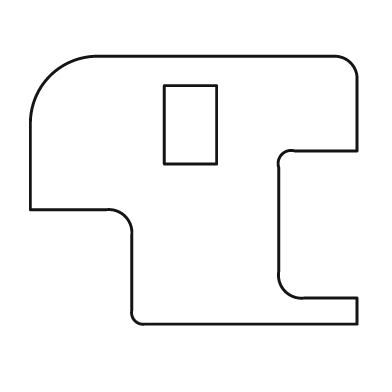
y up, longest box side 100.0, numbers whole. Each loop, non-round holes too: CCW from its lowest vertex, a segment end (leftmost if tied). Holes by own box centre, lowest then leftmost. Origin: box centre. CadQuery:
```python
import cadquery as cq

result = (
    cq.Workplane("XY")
    .moveTo(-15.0, -41.0)
    .lineTo(50.0, -41.0)
    .lineTo(50.0, -33.0)
    .lineTo(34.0, -33.0)
    .threePointArc((28.0, -31.0), (26.0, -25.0))
    .lineTo(26.0, 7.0)
    .threePointArc((27.0, 11.0), (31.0, 12.0))
    .lineTo(50.0, 12.0)
    .lineTo(50.0, 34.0)
    .threePointArc((48.0, 39.0), (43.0, 41.0))
    .lineTo(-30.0, 41.0)
    .threePointArc((-44.0, 35.0), (-50.0, 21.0))
    .lineTo(-50.0, -6.0)
    .lineTo(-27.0, -6.0)
    .threePointArc((-21.0, -8.0), (-19.0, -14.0))
    .lineTo(-19.0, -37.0)
    .threePointArc((-18.0, -40.0), (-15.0, -41.0))
    .close()
    .moveTo(-9.0, 8.0)
    .lineTo(7.0, 8.0)
    .lineTo(7.0, 32.0)
    .lineTo(-9.0, 32.0)
    .close()
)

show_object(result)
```